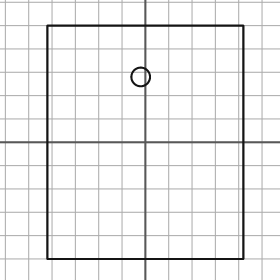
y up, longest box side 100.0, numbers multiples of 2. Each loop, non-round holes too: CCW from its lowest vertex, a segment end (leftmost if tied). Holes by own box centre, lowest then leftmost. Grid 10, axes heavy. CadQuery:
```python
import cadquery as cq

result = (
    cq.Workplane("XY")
    .moveTo(-42.0, -50.0)
    .lineTo(42.0, -50.0)
    .lineTo(42.0, 50.0)
    .lineTo(-42.0, 50.0)
    .close()
    .moveTo(-2.0, 28.0)
    .circle(4.0)
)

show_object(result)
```